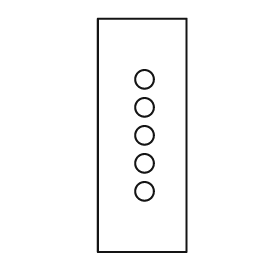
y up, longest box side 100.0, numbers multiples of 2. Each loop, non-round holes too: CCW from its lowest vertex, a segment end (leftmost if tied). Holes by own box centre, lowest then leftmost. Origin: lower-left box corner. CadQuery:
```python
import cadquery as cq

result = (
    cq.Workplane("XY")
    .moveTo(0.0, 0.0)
    .lineTo(38.0, 0.0)
    .lineTo(38.0, 100.0)
    .lineTo(0.0, 100.0)
    .close()
    .moveTo(20.0, 26.0)
    .circle(4.0)
    .moveTo(20.0, 38.0)
    .circle(4.0)
    .moveTo(20.0, 50.0)
    .circle(4.0)
    .moveTo(20.0, 62.0)
    .circle(4.0)
    .moveTo(20.0, 74.0)
    .circle(4.0)
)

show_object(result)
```